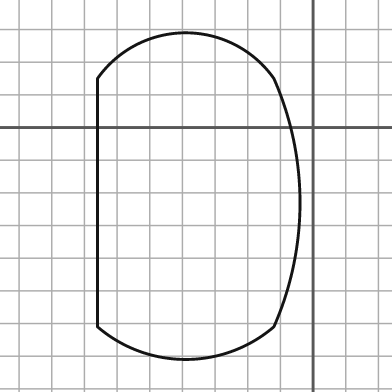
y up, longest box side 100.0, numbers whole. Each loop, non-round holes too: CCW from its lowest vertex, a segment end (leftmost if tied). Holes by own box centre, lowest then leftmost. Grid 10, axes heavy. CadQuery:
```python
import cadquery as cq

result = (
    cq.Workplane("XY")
    .moveTo(-66.0, -61.0)
    .threePointArc((-39.0, -71.0), (-12.0, -61.0))
    .threePointArc((-4.0, -23.0), (-12.0, 15.0))
    .threePointArc((-39.0, 29.0), (-66.0, 15.0))
    .close()
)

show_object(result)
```